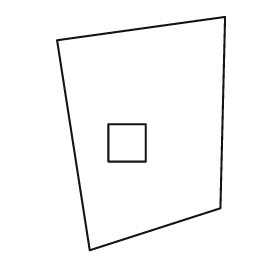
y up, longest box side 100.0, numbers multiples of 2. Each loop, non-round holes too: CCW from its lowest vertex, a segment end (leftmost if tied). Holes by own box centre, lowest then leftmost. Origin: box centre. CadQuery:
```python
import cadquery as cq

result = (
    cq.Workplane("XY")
    .moveTo(-22.0, -50.0)
    .lineTo(34.0, -32.0)
    .lineTo(36.0, 50.0)
    .lineTo(-36.0, 40.0)
    .close()
    .moveTo(-14.0, -12.0)
    .lineTo(2.0, -12.0)
    .lineTo(2.0, 4.0)
    .lineTo(-14.0, 4.0)
    .close()
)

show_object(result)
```